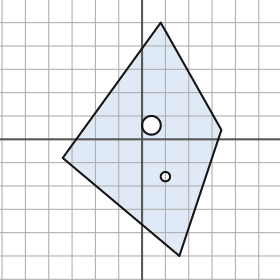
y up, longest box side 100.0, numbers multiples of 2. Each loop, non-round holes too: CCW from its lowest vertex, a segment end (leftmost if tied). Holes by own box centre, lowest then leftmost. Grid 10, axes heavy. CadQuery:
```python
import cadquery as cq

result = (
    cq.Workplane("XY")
    .moveTo(16.0, -50.0)
    .lineTo(34.0, 4.0)
    .lineTo(8.0, 50.0)
    .lineTo(-34.0, -8.0)
    .close()
    .moveTo(10.0, -16.0)
    .circle(2.0)
    .moveTo(4.0, 6.0)
    .circle(4.0)
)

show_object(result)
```